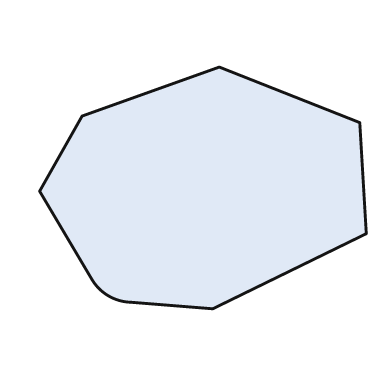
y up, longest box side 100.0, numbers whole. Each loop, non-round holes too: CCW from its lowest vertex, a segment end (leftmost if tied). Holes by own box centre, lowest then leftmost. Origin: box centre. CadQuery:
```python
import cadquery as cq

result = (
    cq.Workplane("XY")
    .moveTo(3.0, -37.0)
    .lineTo(50.0, -14.0)
    .lineTo(48.0, 20.0)
    .lineTo(5.0, 37.0)
    .lineTo(-37.0, 22.0)
    .lineTo(-50.0, -1.0)
    .lineTo(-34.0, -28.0)
    .threePointArc((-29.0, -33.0), (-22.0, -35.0))
    .close()
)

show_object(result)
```